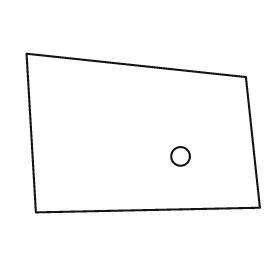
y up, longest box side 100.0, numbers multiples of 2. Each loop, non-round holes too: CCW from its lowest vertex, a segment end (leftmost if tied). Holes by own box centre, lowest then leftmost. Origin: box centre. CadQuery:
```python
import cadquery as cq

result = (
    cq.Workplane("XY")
    .moveTo(-46.0, -34.0)
    .lineTo(50.0, -32.0)
    .lineTo(44.0, 24.0)
    .lineTo(-50.0, 34.0)
    .close()
    .moveTo(16.0, -10.0)
    .circle(4.0)
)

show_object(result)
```